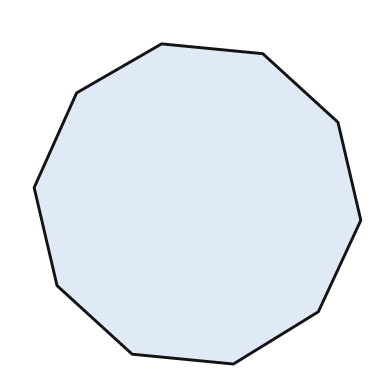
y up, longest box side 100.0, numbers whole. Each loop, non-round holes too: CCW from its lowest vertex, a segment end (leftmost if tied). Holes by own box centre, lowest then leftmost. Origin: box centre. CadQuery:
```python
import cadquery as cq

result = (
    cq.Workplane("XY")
    .moveTo(11.0, -49.0)
    .lineTo(37.0, -33.0)
    .lineTo(50.0, -5.0)
    .lineTo(43.0, 25.0)
    .lineTo(20.0, 46.0)
    .lineTo(-11.0, 49.0)
    .lineTo(-37.0, 34.0)
    .lineTo(-50.0, 5.0)
    .lineTo(-43.0, -25.0)
    .lineTo(-20.0, -46.0)
    .close()
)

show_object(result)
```